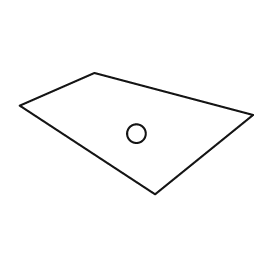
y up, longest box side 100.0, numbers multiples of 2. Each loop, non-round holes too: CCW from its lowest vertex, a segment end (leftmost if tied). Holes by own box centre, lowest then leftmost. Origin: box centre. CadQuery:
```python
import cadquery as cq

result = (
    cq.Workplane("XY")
    .moveTo(8.0, -26.0)
    .lineTo(50.0, 8.0)
    .lineTo(-18.0, 26.0)
    .lineTo(-50.0, 12.0)
    .close()
    .moveTo(0.0, 0.0)
    .circle(4.0)
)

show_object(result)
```